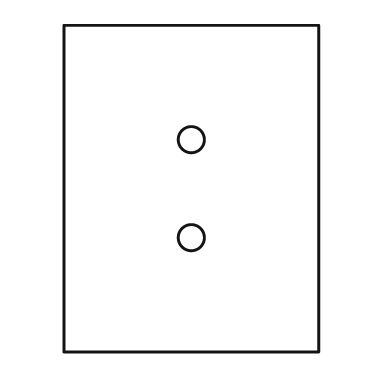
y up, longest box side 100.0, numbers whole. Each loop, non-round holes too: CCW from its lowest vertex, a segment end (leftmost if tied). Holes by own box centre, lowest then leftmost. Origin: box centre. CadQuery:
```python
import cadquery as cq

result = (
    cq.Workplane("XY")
    .moveTo(-39.0, -50.0)
    .lineTo(39.0, -50.0)
    .lineTo(39.0, 50.0)
    .lineTo(-39.0, 50.0)
    .close()
    .moveTo(0.0, -15.0)
    .circle(4.0)
    .moveTo(0.0, 15.0)
    .circle(4.0)
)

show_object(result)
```